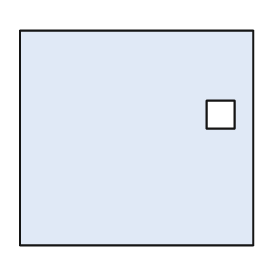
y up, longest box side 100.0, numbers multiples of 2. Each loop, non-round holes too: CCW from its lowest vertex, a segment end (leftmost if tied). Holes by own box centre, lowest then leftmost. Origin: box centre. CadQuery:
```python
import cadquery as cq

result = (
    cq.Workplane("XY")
    .moveTo(-50.0, -46.0)
    .lineTo(50.0, -46.0)
    .lineTo(50.0, 46.0)
    .lineTo(-50.0, 46.0)
    .close()
    .moveTo(30.0, 4.0)
    .lineTo(42.0, 4.0)
    .lineTo(42.0, 16.0)
    .lineTo(30.0, 16.0)
    .close()
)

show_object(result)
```